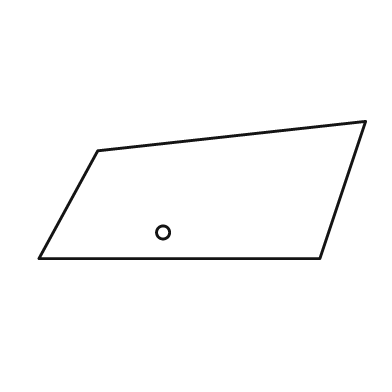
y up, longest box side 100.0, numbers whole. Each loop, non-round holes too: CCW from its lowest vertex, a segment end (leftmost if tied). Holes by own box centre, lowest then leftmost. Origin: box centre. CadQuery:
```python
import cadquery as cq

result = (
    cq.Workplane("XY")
    .moveTo(-50.0, -21.0)
    .lineTo(36.0, -21.0)
    .lineTo(50.0, 21.0)
    .lineTo(-32.0, 12.0)
    .close()
    .moveTo(-12.0, -13.0)
    .circle(2.0)
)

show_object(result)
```